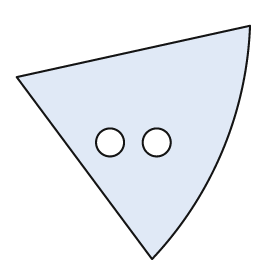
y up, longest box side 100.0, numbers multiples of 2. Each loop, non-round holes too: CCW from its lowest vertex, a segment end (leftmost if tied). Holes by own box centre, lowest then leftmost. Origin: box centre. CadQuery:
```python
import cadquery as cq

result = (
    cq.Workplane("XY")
    .moveTo(8.0, -50.0)
    .threePointArc((38.0, -4.0), (50.0, 50.0))
    .lineTo(-50.0, 28.0)
    .close()
    .moveTo(-10.0, 0.0)
    .circle(6.0)
    .moveTo(10.0, 0.0)
    .circle(6.0)
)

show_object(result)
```